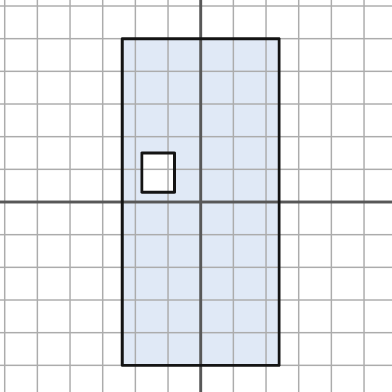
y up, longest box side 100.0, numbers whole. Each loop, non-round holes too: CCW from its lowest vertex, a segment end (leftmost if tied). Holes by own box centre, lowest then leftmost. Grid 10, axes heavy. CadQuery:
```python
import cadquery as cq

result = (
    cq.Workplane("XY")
    .moveTo(-24.0, -50.0)
    .lineTo(24.0, -50.0)
    .lineTo(24.0, 50.0)
    .lineTo(-24.0, 50.0)
    .close()
    .moveTo(-18.0, 3.0)
    .lineTo(-8.0, 3.0)
    .lineTo(-8.0, 15.0)
    .lineTo(-18.0, 15.0)
    .close()
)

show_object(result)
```